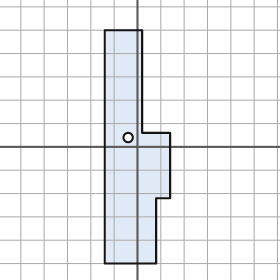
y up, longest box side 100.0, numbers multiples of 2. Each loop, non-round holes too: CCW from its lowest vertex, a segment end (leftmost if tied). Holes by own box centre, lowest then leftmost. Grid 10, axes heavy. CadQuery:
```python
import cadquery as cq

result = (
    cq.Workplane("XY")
    .moveTo(-14.0, -50.0)
    .lineTo(8.0, -50.0)
    .lineTo(8.0, -22.0)
    .lineTo(14.0, -22.0)
    .lineTo(14.0, 6.0)
    .lineTo(2.0, 6.0)
    .lineTo(2.0, 50.0)
    .lineTo(-14.0, 50.0)
    .close()
    .moveTo(-4.0, 4.0)
    .circle(2.0)
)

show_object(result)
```